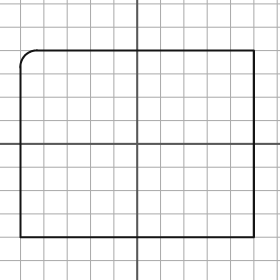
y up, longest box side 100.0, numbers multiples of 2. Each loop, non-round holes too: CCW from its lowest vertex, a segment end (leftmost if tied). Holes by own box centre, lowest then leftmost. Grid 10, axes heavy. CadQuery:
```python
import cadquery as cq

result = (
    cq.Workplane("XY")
    .moveTo(-50.0, -40.0)
    .lineTo(50.0, -40.0)
    .lineTo(50.0, 40.0)
    .lineTo(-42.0, 40.0)
    .threePointArc((-48.0, 38.0), (-50.0, 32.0))
    .close()
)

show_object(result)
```